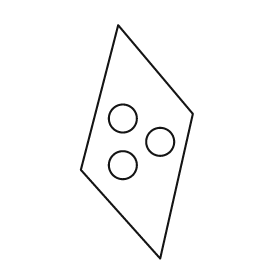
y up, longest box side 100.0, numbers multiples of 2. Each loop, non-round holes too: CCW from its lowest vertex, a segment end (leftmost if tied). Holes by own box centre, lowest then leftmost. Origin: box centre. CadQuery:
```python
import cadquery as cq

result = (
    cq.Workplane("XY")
    .moveTo(10.0, -50.0)
    .lineTo(24.0, 12.0)
    .lineTo(-8.0, 50.0)
    .lineTo(-24.0, -12.0)
    .close()
    .moveTo(-6.0, -10.0)
    .circle(6.0)
    .moveTo(10.0, 0.0)
    .circle(6.0)
    .moveTo(-6.0, 10.0)
    .circle(6.0)
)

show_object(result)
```